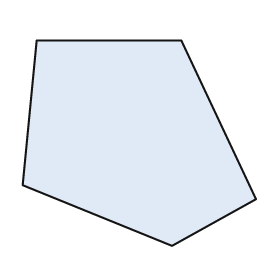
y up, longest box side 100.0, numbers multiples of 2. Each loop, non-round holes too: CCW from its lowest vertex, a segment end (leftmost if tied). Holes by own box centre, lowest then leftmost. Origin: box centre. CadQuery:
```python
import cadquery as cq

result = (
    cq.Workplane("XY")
    .moveTo(14.0, -44.0)
    .lineTo(50.0, -24.0)
    .lineTo(18.0, 44.0)
    .lineTo(-44.0, 44.0)
    .lineTo(-50.0, -18.0)
    .close()
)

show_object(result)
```